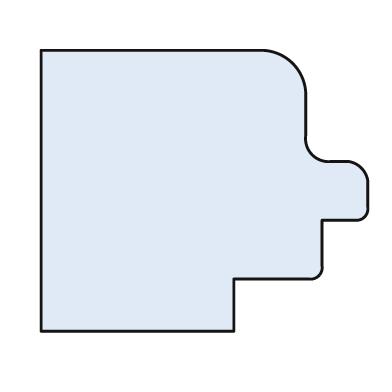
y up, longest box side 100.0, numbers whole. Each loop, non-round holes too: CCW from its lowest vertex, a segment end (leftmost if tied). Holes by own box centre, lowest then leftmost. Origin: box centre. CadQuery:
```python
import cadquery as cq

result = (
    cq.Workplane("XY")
    .moveTo(-50.0, -43.0)
    .lineTo(9.0, -43.0)
    .lineTo(9.0, -27.0)
    .lineTo(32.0, -27.0)
    .threePointArc((35.0, -26.0), (36.0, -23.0))
    .lineTo(36.0, -9.0)
    .lineTo(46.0, -9.0)
    .threePointArc((49.0, -8.0), (50.0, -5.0))
    .lineTo(50.0, 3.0)
    .threePointArc((48.0, 7.0), (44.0, 9.0))
    .lineTo(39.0, 9.0)
    .threePointArc((33.0, 11.0), (31.0, 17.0))
    .lineTo(31.0, 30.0)
    .threePointArc((27.0, 39.0), (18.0, 43.0))
    .lineTo(-50.0, 43.0)
    .close()
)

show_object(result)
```